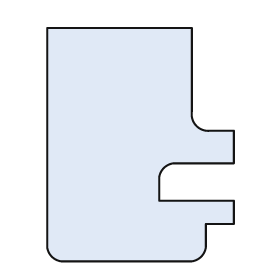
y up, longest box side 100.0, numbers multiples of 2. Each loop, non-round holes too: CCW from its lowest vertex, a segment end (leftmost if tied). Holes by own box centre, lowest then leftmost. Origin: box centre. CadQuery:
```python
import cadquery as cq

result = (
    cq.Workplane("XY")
    .moveTo(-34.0, -50.0)
    .lineTo(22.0, -50.0)
    .threePointArc((26.0, -48.0), (28.0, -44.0))
    .lineTo(28.0, -34.0)
    .lineTo(40.0, -34.0)
    .lineTo(40.0, -24.0)
    .lineTo(8.0, -24.0)
    .lineTo(8.0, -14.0)
    .threePointArc((10.0, -10.0), (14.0, -8.0))
    .lineTo(40.0, -8.0)
    .lineTo(40.0, 6.0)
    .lineTo(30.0, 6.0)
    .threePointArc((24.0, 8.0), (22.0, 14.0))
    .lineTo(22.0, 50.0)
    .lineTo(-40.0, 50.0)
    .lineTo(-40.0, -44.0)
    .threePointArc((-38.0, -48.0), (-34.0, -50.0))
    .close()
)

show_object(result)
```